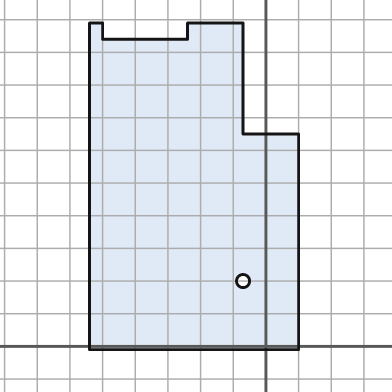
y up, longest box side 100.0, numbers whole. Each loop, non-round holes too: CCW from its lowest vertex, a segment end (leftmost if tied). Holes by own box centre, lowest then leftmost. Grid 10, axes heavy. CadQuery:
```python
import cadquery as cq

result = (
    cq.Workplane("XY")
    .moveTo(-54.0, -1.0)
    .lineTo(10.0, -1.0)
    .lineTo(10.0, 65.0)
    .lineTo(-7.0, 65.0)
    .lineTo(-7.0, 99.0)
    .lineTo(-24.0, 99.0)
    .lineTo(-24.0, 94.0)
    .lineTo(-50.0, 94.0)
    .lineTo(-50.0, 99.0)
    .lineTo(-54.0, 99.0)
    .close()
    .moveTo(-7.0, 20.0)
    .circle(2.0)
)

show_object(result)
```